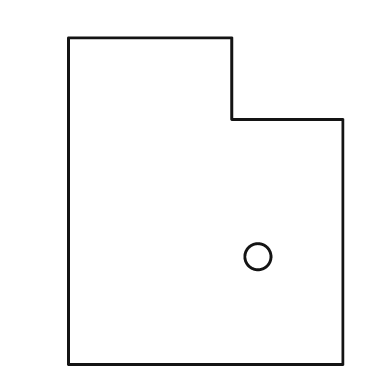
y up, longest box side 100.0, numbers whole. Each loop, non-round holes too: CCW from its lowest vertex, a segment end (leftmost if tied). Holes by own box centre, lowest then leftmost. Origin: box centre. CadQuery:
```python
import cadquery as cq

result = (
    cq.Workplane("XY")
    .moveTo(-42.0, -50.0)
    .lineTo(42.0, -50.0)
    .lineTo(42.0, 25.0)
    .lineTo(8.0, 25.0)
    .lineTo(8.0, 50.0)
    .lineTo(-42.0, 50.0)
    .close()
    .moveTo(16.0, -17.0)
    .circle(4.0)
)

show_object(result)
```